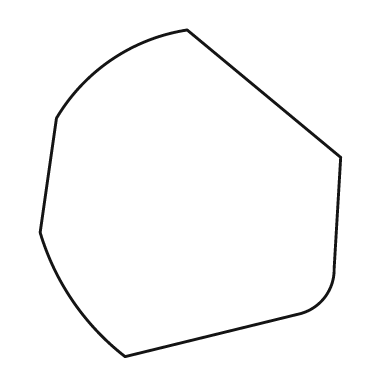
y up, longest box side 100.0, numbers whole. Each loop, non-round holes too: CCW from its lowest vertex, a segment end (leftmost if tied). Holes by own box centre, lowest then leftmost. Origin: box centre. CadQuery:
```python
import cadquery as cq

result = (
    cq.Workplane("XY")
    .moveTo(-20.0, -50.0)
    .lineTo(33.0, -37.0)
    .threePointArc((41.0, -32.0), (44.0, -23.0))
    .lineTo(46.0, 11.0)
    .lineTo(-1.0, 50.0)
    .threePointArc((-24.0, 41.0), (-41.0, 23.0))
    .lineTo(-46.0, -12.0)
    .threePointArc((-36.0, -33.0), (-20.0, -50.0))
    .close()
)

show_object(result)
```